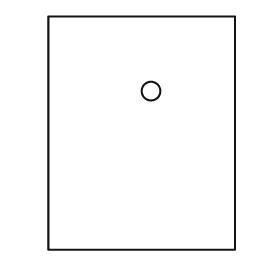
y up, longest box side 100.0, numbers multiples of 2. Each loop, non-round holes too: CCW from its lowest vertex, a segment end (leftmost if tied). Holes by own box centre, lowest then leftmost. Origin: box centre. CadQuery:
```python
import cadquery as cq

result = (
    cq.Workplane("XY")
    .moveTo(-40.0, -50.0)
    .lineTo(40.0, -50.0)
    .lineTo(40.0, 50.0)
    .lineTo(-40.0, 50.0)
    .close()
    .moveTo(4.0, 18.0)
    .circle(4.0)
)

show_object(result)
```